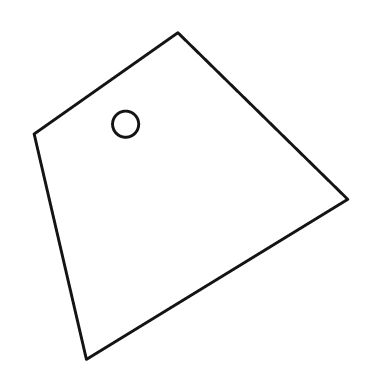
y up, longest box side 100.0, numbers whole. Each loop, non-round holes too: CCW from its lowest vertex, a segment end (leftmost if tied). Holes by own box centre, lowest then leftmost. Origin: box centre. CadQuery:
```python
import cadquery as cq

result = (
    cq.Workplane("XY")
    .moveTo(-32.0, -50.0)
    .lineTo(48.0, -1.0)
    .lineTo(-4.0, 50.0)
    .lineTo(-48.0, 19.0)
    .close()
    .moveTo(-20.0, 22.0)
    .circle(4.0)
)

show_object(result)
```